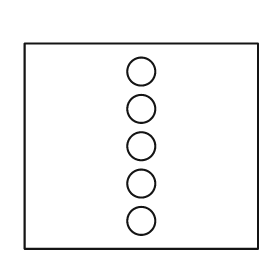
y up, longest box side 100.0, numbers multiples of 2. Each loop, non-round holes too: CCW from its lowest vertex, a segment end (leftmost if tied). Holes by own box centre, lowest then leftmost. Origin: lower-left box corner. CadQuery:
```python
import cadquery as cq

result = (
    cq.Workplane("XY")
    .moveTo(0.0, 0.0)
    .lineTo(100.0, 0.0)
    .lineTo(100.0, 88.0)
    .lineTo(0.0, 88.0)
    .close()
    .moveTo(50.0, 12.0)
    .circle(6.0)
    .moveTo(50.0, 28.0)
    .circle(6.0)
    .moveTo(50.0, 44.0)
    .circle(6.0)
    .moveTo(50.0, 60.0)
    .circle(6.0)
    .moveTo(50.0, 76.0)
    .circle(6.0)
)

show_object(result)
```